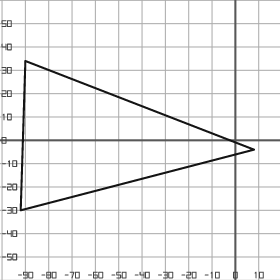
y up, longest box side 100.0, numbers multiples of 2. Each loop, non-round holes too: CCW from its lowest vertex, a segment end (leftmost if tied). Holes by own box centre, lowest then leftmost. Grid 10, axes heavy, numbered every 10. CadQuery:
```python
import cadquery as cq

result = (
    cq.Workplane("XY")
    .moveTo(-92.0, -30.0)
    .lineTo(8.0, -4.0)
    .lineTo(-90.0, 34.0)
    .close()
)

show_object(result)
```